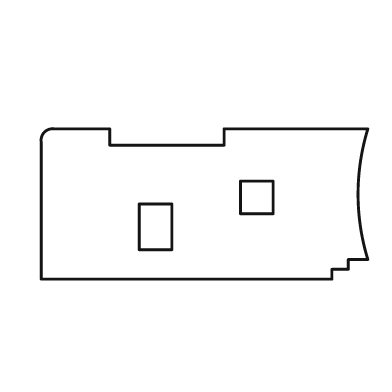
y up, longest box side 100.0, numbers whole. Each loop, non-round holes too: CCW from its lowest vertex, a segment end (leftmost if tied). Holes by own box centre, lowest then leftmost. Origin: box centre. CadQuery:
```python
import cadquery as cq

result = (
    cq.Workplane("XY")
    .moveTo(-50.0, -23.0)
    .lineTo(39.0, -23.0)
    .lineTo(39.0, -20.0)
    .lineTo(44.0, -20.0)
    .lineTo(44.0, -17.0)
    .lineTo(50.0, -17.0)
    .threePointArc((47.0, 3.0), (50.0, 23.0))
    .lineTo(6.0, 23.0)
    .lineTo(6.0, 18.0)
    .lineTo(-29.0, 18.0)
    .lineTo(-29.0, 23.0)
    .lineTo(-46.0, 23.0)
    .threePointArc((-49.0, 22.0), (-50.0, 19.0))
    .close()
    .moveTo(-20.0, -14.0)
    .lineTo(-10.0, -14.0)
    .lineTo(-10.0, 0.0)
    .lineTo(-20.0, 0.0)
    .close()
    .moveTo(11.0, -3.0)
    .lineTo(21.0, -3.0)
    .lineTo(21.0, 7.0)
    .lineTo(11.0, 7.0)
    .close()
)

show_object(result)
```